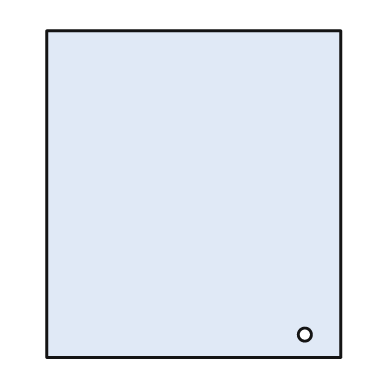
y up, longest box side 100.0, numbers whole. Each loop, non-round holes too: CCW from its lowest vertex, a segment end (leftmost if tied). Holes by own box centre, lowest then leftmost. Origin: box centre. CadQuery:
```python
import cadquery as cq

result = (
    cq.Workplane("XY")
    .moveTo(-45.0, -50.0)
    .lineTo(45.0, -50.0)
    .lineTo(45.0, 50.0)
    .lineTo(-45.0, 50.0)
    .close()
    .moveTo(34.0, -43.0)
    .circle(2.0)
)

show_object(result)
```